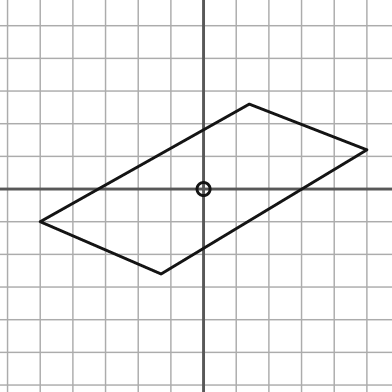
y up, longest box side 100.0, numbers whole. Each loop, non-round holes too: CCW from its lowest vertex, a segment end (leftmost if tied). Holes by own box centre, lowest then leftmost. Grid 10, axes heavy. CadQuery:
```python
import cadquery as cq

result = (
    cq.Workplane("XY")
    .moveTo(-13.0, -26.0)
    .lineTo(50.0, 12.0)
    .lineTo(14.0, 26.0)
    .lineTo(-50.0, -10.0)
    .close()
    .moveTo(0.0, 0.0)
    .circle(2.0)
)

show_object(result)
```